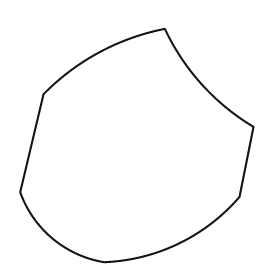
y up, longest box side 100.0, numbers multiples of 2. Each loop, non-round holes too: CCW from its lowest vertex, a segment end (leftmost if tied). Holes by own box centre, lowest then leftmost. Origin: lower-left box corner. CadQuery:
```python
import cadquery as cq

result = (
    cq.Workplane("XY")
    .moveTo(36.0, 0.0)
    .threePointArc((68.0, 8.0), (94.0, 28.0))
    .lineTo(100.0, 58.0)
    .threePointArc((78.0, 76.0), (62.0, 100.0))
    .threePointArc((34.0, 90.0), (10.0, 72.0))
    .lineTo(0.0, 30.0)
    .threePointArc((14.0, 10.0), (36.0, 0.0))
    .close()
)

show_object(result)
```